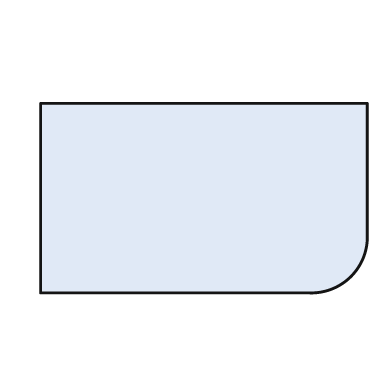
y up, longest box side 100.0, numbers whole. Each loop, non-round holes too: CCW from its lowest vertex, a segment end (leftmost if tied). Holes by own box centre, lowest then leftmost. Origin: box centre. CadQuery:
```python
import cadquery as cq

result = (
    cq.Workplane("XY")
    .moveTo(-50.0, -29.0)
    .lineTo(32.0, -29.0)
    .threePointArc((45.0, -24.0), (50.0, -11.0))
    .lineTo(50.0, 29.0)
    .lineTo(-50.0, 29.0)
    .close()
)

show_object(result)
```